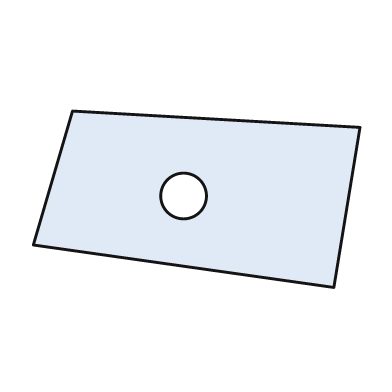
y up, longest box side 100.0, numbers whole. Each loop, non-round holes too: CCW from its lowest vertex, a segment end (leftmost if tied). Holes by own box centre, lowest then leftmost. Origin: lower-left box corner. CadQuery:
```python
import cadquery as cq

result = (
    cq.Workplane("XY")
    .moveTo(92.0, 0.0)
    .lineTo(100.0, 49.0)
    .lineTo(12.0, 54.0)
    .lineTo(0.0, 13.0)
    .close()
    .moveTo(46.0, 28.0)
    .circle(7.0)
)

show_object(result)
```